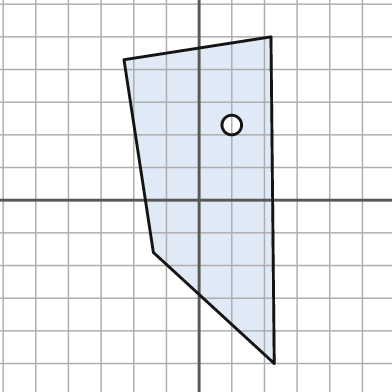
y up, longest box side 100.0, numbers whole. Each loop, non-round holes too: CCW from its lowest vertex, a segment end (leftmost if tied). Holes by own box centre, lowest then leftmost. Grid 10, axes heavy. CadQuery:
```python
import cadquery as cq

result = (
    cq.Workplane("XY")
    .moveTo(23.0, -50.0)
    .lineTo(22.0, 50.0)
    .lineTo(-23.0, 43.0)
    .lineTo(-14.0, -16.0)
    .close()
    .moveTo(10.0, 23.0)
    .circle(3.0)
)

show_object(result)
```